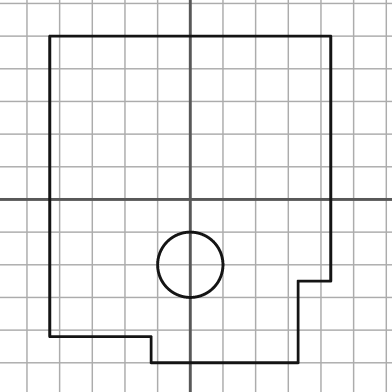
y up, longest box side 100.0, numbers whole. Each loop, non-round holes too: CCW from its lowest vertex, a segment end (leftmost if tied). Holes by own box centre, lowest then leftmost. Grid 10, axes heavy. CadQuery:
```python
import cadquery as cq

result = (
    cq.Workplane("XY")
    .moveTo(-12.0, -50.0)
    .lineTo(33.0, -50.0)
    .lineTo(33.0, -25.0)
    .lineTo(43.0, -25.0)
    .lineTo(43.0, 50.0)
    .lineTo(-43.0, 50.0)
    .lineTo(-43.0, -42.0)
    .lineTo(-12.0, -42.0)
    .close()
    .moveTo(0.0, -20.0)
    .circle(10.0)
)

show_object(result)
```